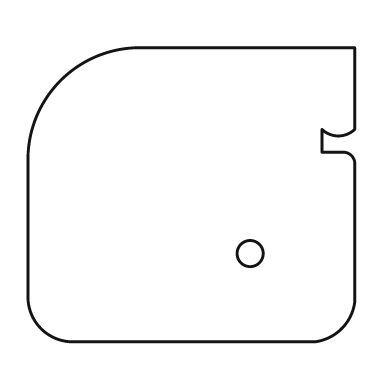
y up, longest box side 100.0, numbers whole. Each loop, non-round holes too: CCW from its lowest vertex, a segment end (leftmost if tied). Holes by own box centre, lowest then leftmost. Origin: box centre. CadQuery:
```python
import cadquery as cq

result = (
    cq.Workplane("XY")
    .moveTo(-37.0, -45.0)
    .lineTo(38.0, -45.0)
    .threePointArc((46.0, -41.0), (50.0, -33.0))
    .lineTo(50.0, 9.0)
    .threePointArc((49.0, 12.0), (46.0, 13.0))
    .lineTo(40.0, 13.0)
    .lineTo(40.0, 20.0)
    .threePointArc((45.0, 18.0), (50.0, 20.0))
    .lineTo(50.0, 45.0)
    .lineTo(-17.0, 45.0)
    .threePointArc((-40.0, 35.0), (-50.0, 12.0))
    .lineTo(-50.0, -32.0)
    .threePointArc((-46.0, -41.0), (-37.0, -45.0))
    .close()
    .moveTo(18.0, -18.0)
    .circle(4.0)
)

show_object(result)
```